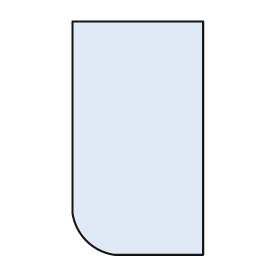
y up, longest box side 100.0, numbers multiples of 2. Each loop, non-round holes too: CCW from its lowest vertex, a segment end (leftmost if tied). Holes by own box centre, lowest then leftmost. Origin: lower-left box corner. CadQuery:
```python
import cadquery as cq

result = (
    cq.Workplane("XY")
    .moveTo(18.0, 0.0)
    .lineTo(56.0, 0.0)
    .lineTo(56.0, 100.0)
    .lineTo(0.0, 100.0)
    .lineTo(0.0, 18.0)
    .threePointArc((6.0, 6.0), (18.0, 0.0))
    .close()
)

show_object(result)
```